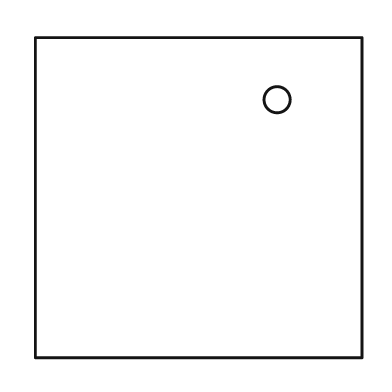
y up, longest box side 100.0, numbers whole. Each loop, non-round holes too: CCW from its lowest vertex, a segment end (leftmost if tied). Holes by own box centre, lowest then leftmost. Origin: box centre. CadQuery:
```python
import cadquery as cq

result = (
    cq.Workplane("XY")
    .moveTo(-50.0, -49.0)
    .lineTo(50.0, -49.0)
    .lineTo(50.0, 49.0)
    .lineTo(-50.0, 49.0)
    .close()
    .moveTo(24.0, 30.0)
    .circle(4.0)
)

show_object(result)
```